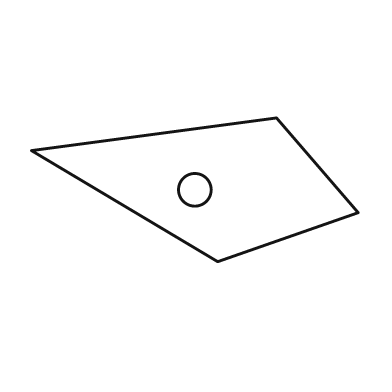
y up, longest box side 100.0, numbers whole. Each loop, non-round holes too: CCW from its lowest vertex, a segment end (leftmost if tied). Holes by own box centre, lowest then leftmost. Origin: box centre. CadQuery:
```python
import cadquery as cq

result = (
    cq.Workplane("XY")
    .moveTo(7.0, -22.0)
    .lineTo(50.0, -7.0)
    .lineTo(25.0, 22.0)
    .lineTo(-50.0, 12.0)
    .close()
    .moveTo(0.0, 0.0)
    .circle(5.0)
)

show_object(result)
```